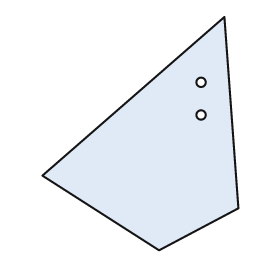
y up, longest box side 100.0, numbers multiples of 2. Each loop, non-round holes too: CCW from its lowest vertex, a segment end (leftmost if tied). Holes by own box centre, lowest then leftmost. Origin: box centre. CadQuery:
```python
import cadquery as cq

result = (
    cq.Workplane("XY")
    .moveTo(8.0, -50.0)
    .lineTo(42.0, -32.0)
    .lineTo(36.0, 50.0)
    .lineTo(-42.0, -18.0)
    .close()
    .moveTo(26.0, 8.0)
    .circle(2.0)
    .moveTo(26.0, 22.0)
    .circle(2.0)
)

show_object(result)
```